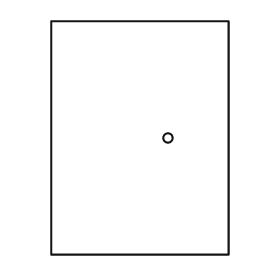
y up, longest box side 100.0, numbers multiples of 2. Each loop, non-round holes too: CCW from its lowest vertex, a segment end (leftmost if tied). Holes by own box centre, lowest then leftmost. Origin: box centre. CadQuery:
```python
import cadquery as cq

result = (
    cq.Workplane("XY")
    .moveTo(-38.0, -50.0)
    .lineTo(38.0, -50.0)
    .lineTo(38.0, 50.0)
    .lineTo(-38.0, 50.0)
    .close()
    .moveTo(12.0, 0.0)
    .circle(2.0)
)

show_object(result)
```